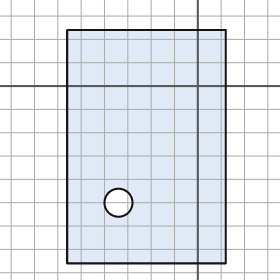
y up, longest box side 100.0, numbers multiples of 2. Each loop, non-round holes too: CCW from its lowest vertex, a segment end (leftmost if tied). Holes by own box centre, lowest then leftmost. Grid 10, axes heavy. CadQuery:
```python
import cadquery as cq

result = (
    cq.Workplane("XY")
    .moveTo(-56.0, -76.0)
    .lineTo(12.0, -76.0)
    .lineTo(12.0, 24.0)
    .lineTo(-56.0, 24.0)
    .close()
    .moveTo(-34.0, -50.0)
    .circle(6.0)
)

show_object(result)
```